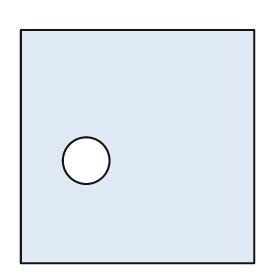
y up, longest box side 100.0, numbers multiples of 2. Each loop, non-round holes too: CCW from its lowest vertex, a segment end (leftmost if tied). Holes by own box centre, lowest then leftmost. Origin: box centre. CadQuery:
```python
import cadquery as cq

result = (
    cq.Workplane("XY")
    .moveTo(-50.0, -50.0)
    .lineTo(50.0, -50.0)
    .lineTo(50.0, 50.0)
    .lineTo(-50.0, 50.0)
    .close()
    .moveTo(-22.0, -6.0)
    .circle(10.0)
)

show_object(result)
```